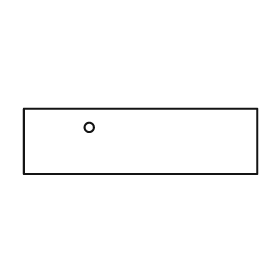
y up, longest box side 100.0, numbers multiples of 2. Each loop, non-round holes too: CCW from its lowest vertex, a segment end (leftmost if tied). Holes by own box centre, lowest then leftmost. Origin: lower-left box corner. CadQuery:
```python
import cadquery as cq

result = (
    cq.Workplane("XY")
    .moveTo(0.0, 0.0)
    .lineTo(100.0, 0.0)
    .lineTo(100.0, 28.0)
    .lineTo(0.0, 28.0)
    .close()
    .moveTo(28.0, 20.0)
    .circle(2.0)
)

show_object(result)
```